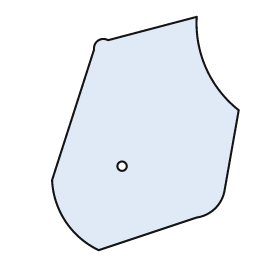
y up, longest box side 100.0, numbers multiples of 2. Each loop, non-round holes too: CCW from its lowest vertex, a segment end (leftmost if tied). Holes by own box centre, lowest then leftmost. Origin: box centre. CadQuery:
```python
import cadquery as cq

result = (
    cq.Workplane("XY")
    .moveTo(-20.0, -50.0)
    .lineTo(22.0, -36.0)
    .threePointArc((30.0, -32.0), (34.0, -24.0))
    .lineTo(40.0, 10.0)
    .threePointArc((26.0, 28.0), (22.0, 50.0))
    .lineTo(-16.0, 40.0)
    .threePointArc((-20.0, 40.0), (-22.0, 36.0))
    .lineTo(-40.0, -20.0)
    .threePointArc((-34.0, -38.0), (-20.0, -50.0))
    .close()
    .moveTo(-10.0, -14.0)
    .circle(2.0)
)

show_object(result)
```